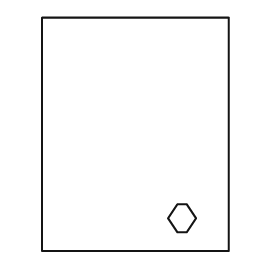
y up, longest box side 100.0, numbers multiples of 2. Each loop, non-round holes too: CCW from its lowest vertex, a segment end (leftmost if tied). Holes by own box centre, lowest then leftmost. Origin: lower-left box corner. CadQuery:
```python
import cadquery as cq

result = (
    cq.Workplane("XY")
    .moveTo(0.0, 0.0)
    .lineTo(80.0, 0.0)
    .lineTo(80.0, 100.0)
    .lineTo(0.0, 100.0)
    .close()
    .moveTo(58.0, 8.0)
    .lineTo(62.0, 8.0)
    .lineTo(66.0, 14.0)
    .lineTo(62.0, 20.0)
    .lineTo(58.0, 20.0)
    .lineTo(54.0, 14.0)
    .close()
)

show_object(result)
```